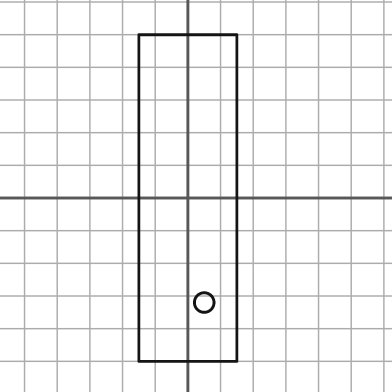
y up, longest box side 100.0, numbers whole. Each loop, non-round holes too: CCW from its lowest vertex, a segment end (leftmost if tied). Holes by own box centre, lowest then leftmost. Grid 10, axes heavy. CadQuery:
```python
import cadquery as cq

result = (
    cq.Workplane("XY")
    .moveTo(-15.0, -50.0)
    .lineTo(15.0, -50.0)
    .lineTo(15.0, 50.0)
    .lineTo(-15.0, 50.0)
    .close()
    .moveTo(5.0, -32.0)
    .circle(3.0)
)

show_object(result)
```